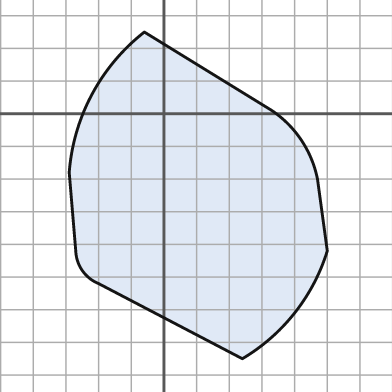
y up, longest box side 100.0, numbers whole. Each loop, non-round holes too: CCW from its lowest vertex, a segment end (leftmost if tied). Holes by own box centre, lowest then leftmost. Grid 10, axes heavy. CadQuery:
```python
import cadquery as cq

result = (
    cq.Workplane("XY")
    .moveTo(24.0, -75.0)
    .threePointArc((40.0, -61.0), (50.0, -42.0))
    .lineTo(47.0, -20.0)
    .threePointArc((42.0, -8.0), (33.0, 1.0))
    .lineTo(-6.0, 25.0)
    .threePointArc((-22.0, 6.0), (-29.0, -18.0))
    .lineTo(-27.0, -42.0)
    .threePointArc((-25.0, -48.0), (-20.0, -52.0))
    .close()
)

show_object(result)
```